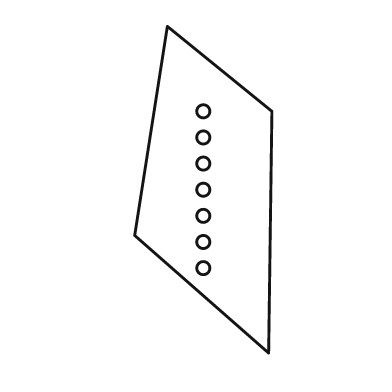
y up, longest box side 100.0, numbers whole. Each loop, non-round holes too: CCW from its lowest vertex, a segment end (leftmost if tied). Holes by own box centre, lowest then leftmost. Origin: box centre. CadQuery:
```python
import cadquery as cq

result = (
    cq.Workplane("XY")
    .moveTo(20.0, -50.0)
    .lineTo(21.0, 24.0)
    .lineTo(-11.0, 50.0)
    .lineTo(-21.0, -14.0)
    .close()
    .moveTo(0.0, -24.0)
    .circle(2.0)
    .moveTo(0.0, -16.0)
    .circle(2.0)
    .moveTo(0.0, -8.0)
    .circle(2.0)
    .moveTo(0.0, 0.0)
    .circle(2.0)
    .moveTo(0.0, 8.0)
    .circle(2.0)
    .moveTo(0.0, 16.0)
    .circle(2.0)
    .moveTo(0.0, 24.0)
    .circle(2.0)
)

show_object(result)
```